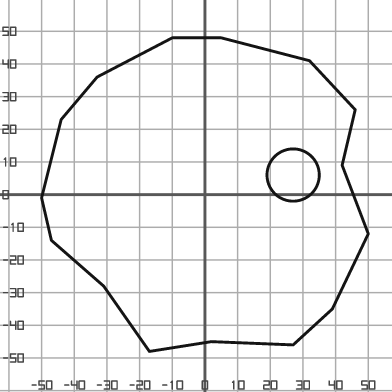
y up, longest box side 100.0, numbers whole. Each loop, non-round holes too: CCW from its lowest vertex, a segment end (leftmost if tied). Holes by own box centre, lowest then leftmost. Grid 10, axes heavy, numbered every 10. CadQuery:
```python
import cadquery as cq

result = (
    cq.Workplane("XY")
    .moveTo(-17.0, -48.0)
    .lineTo(2.0, -45.0)
    .lineTo(27.0, -46.0)
    .lineTo(39.0, -35.0)
    .lineTo(50.0, -12.0)
    .lineTo(42.0, 9.0)
    .lineTo(46.0, 26.0)
    .lineTo(32.0, 41.0)
    .lineTo(5.0, 48.0)
    .lineTo(-10.0, 48.0)
    .lineTo(-33.0, 36.0)
    .lineTo(-44.0, 23.0)
    .lineTo(-50.0, -1.0)
    .lineTo(-47.0, -14.0)
    .lineTo(-31.0, -28.0)
    .close()
    .moveTo(27.0, 6.0)
    .circle(8.0)
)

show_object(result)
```